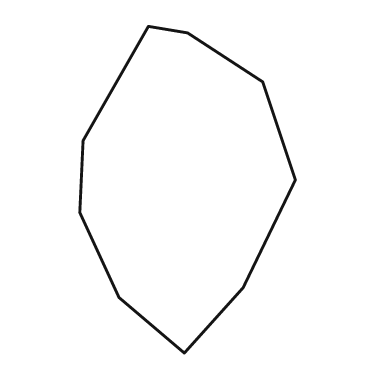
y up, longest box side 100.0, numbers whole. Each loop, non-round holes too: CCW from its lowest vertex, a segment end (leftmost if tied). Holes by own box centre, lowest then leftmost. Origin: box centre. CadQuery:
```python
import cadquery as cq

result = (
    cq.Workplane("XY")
    .moveTo(-1.0, -50.0)
    .lineTo(17.0, -30.0)
    .lineTo(33.0, 3.0)
    .lineTo(23.0, 33.0)
    .lineTo(0.0, 48.0)
    .lineTo(-12.0, 50.0)
    .lineTo(-32.0, 15.0)
    .lineTo(-33.0, -7.0)
    .lineTo(-21.0, -33.0)
    .close()
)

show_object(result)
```